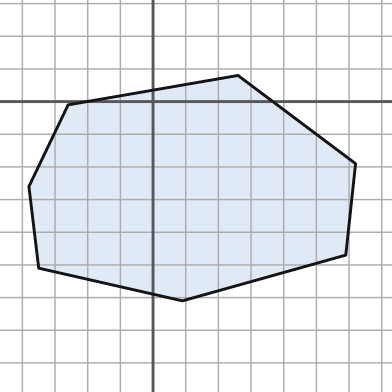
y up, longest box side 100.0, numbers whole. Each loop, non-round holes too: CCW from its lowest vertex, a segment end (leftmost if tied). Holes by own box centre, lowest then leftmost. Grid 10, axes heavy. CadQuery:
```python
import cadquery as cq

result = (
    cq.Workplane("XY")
    .moveTo(9.0, -61.0)
    .lineTo(59.0, -47.0)
    .lineTo(62.0, -19.0)
    .lineTo(26.0, 8.0)
    .lineTo(-26.0, -1.0)
    .lineTo(-38.0, -26.0)
    .lineTo(-35.0, -51.0)
    .close()
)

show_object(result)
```